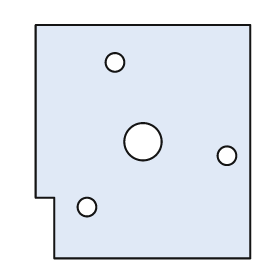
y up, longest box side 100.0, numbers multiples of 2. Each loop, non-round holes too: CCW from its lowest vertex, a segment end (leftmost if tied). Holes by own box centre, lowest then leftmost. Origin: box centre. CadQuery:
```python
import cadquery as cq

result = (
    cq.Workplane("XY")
    .moveTo(-38.0, -50.0)
    .lineTo(46.0, -50.0)
    .lineTo(46.0, 50.0)
    .lineTo(-46.0, 50.0)
    .lineTo(-46.0, -24.0)
    .lineTo(-38.0, -24.0)
    .close()
    .moveTo(-24.0, -28.0)
    .circle(4.0)
    .moveTo(36.0, -6.0)
    .circle(4.0)
    .moveTo(0.0, 0.0)
    .circle(8.0)
    .moveTo(-12.0, 34.0)
    .circle(4.0)
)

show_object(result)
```